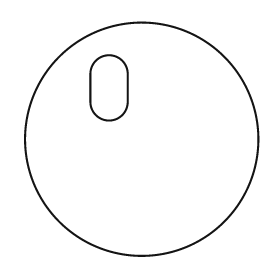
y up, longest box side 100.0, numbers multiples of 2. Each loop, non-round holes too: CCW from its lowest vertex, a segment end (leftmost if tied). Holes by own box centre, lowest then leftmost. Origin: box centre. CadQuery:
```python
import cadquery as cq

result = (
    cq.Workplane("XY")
    .moveTo(0.0, 0.0)
    .circle(50.0)
    .moveTo(-22.0, 16.0)
    .threePointArc((-14.0, 8.0), (-6.0, 16.0))
    .lineTo(-6.0, 28.0)
    .threePointArc((-14.0, 36.0), (-22.0, 28.0))
    .close()
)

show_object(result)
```